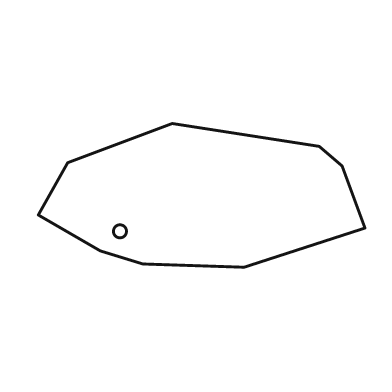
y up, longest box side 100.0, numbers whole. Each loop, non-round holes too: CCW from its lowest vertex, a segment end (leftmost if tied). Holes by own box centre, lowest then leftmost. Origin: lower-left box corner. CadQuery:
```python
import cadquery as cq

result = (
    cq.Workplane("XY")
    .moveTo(63.0, 0.0)
    .lineTo(100.0, 12.0)
    .lineTo(93.0, 31.0)
    .lineTo(86.0, 37.0)
    .lineTo(41.0, 44.0)
    .lineTo(9.0, 32.0)
    .lineTo(0.0, 16.0)
    .lineTo(19.0, 5.0)
    .lineTo(32.0, 1.0)
    .close()
    .moveTo(25.0, 11.0)
    .circle(2.0)
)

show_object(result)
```